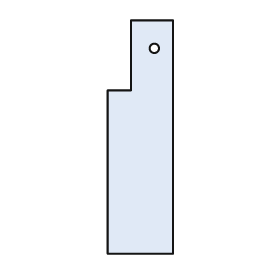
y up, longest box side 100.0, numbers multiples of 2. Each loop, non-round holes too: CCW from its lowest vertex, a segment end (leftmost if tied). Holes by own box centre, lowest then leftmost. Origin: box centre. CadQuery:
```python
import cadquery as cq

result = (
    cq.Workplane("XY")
    .moveTo(-14.0, -50.0)
    .lineTo(14.0, -50.0)
    .lineTo(14.0, 50.0)
    .lineTo(-4.0, 50.0)
    .lineTo(-4.0, 20.0)
    .lineTo(-14.0, 20.0)
    .close()
    .moveTo(6.0, 38.0)
    .circle(2.0)
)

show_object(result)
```